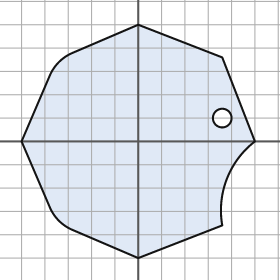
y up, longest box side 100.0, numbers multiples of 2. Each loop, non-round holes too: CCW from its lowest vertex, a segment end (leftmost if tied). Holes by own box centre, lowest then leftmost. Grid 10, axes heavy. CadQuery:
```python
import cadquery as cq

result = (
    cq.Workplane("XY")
    .moveTo(0.0, -50.0)
    .lineTo(36.0, -36.0)
    .threePointArc((38.0, -16.0), (50.0, 0.0))
    .lineTo(36.0, 36.0)
    .lineTo(0.0, 50.0)
    .lineTo(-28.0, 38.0)
    .threePointArc((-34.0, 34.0), (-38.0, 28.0))
    .lineTo(-50.0, 0.0)
    .lineTo(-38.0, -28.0)
    .threePointArc((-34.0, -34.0), (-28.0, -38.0))
    .close()
    .moveTo(36.0, 10.0)
    .circle(4.0)
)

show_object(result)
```